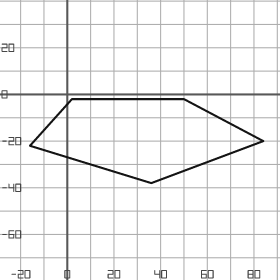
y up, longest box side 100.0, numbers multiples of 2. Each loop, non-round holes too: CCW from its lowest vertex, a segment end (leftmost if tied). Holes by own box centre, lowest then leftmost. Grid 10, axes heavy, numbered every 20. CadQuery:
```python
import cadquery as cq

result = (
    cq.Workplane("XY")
    .moveTo(36.0, -38.0)
    .lineTo(84.0, -20.0)
    .lineTo(50.0, -2.0)
    .lineTo(2.0, -2.0)
    .lineTo(-16.0, -22.0)
    .close()
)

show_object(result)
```